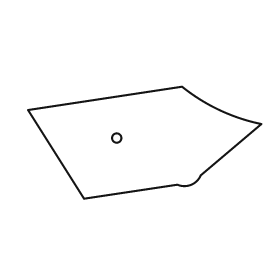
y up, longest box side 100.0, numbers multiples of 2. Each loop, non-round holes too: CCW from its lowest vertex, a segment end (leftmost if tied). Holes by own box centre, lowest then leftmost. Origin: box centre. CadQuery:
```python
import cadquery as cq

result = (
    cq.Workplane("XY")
    .moveTo(-26.0, -24.0)
    .lineTo(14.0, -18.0)
    .threePointArc((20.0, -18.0), (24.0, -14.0))
    .lineTo(50.0, 8.0)
    .threePointArc((32.0, 14.0), (16.0, 24.0))
    .lineTo(-50.0, 14.0)
    .close()
    .moveTo(-12.0, 2.0)
    .circle(2.0)
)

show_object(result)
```